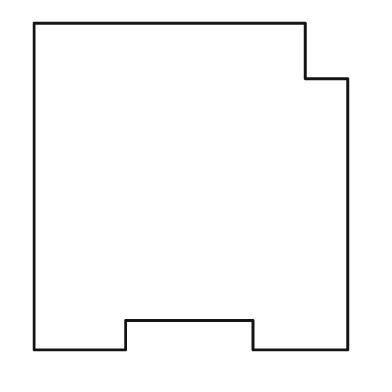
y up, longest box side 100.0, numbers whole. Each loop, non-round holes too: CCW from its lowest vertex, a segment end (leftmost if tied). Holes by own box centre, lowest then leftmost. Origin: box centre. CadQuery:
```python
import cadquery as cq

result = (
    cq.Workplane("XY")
    .moveTo(-48.0, -50.0)
    .lineTo(-20.0, -50.0)
    .lineTo(-20.0, -41.0)
    .lineTo(19.0, -41.0)
    .lineTo(19.0, -50.0)
    .lineTo(48.0, -50.0)
    .lineTo(48.0, 33.0)
    .lineTo(35.0, 33.0)
    .lineTo(35.0, 50.0)
    .lineTo(-48.0, 50.0)
    .close()
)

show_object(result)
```